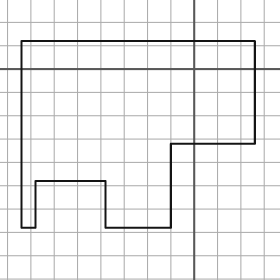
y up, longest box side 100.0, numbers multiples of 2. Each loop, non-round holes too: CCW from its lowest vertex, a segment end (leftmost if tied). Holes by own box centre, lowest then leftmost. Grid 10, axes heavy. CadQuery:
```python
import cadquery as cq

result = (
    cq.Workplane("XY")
    .moveTo(-74.0, -68.0)
    .lineTo(-68.0, -68.0)
    .lineTo(-68.0, -48.0)
    .lineTo(-38.0, -48.0)
    .lineTo(-38.0, -68.0)
    .lineTo(-10.0, -68.0)
    .lineTo(-10.0, -32.0)
    .lineTo(26.0, -32.0)
    .lineTo(26.0, 12.0)
    .lineTo(-74.0, 12.0)
    .close()
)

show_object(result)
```